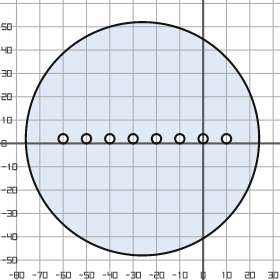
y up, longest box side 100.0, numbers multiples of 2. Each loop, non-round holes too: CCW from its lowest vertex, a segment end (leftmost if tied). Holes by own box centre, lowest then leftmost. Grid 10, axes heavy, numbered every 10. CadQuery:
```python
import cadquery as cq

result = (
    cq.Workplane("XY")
    .moveTo(-26.0, 2.0)
    .circle(50.0)
    .moveTo(-60.0, 2.0)
    .circle(2.0)
    .moveTo(-50.0, 2.0)
    .circle(2.0)
    .moveTo(-40.0, 2.0)
    .circle(2.0)
    .moveTo(-30.0, 2.0)
    .circle(2.0)
    .moveTo(-20.0, 2.0)
    .circle(2.0)
    .moveTo(-10.0, 2.0)
    .circle(2.0)
    .moveTo(0.0, 2.0)
    .circle(2.0)
    .moveTo(10.0, 2.0)
    .circle(2.0)
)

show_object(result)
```